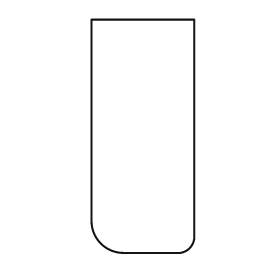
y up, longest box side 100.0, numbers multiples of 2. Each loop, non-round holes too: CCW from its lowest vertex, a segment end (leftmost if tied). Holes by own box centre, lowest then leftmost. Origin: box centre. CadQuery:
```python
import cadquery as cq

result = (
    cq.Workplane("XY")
    .moveTo(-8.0, -50.0)
    .lineTo(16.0, -50.0)
    .threePointArc((20.0, -48.0), (22.0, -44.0))
    .lineTo(22.0, 50.0)
    .lineTo(-22.0, 50.0)
    .lineTo(-22.0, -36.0)
    .threePointArc((-18.0, -46.0), (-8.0, -50.0))
    .close()
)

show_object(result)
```